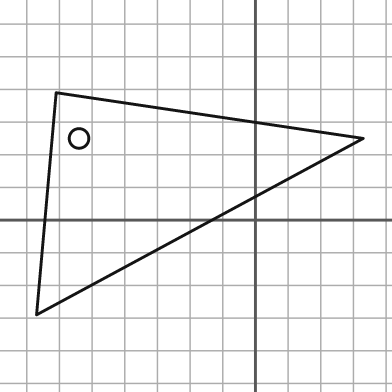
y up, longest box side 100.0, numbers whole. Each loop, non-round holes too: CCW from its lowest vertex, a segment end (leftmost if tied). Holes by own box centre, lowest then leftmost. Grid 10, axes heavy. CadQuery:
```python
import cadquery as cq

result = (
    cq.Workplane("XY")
    .moveTo(-67.0, -29.0)
    .lineTo(33.0, 25.0)
    .lineTo(-61.0, 39.0)
    .close()
    .moveTo(-54.0, 25.0)
    .circle(3.0)
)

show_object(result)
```